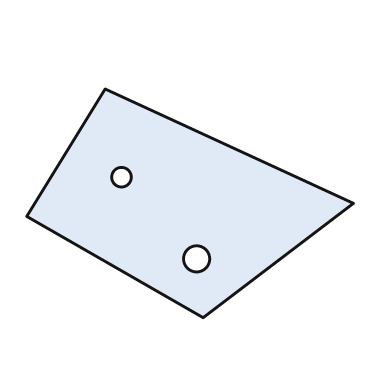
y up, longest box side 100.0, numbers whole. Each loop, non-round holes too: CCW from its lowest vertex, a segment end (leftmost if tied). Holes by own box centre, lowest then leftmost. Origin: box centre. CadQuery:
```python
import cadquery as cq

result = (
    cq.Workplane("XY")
    .moveTo(4.0, -35.0)
    .lineTo(50.0, 0.0)
    .lineTo(-26.0, 35.0)
    .lineTo(-50.0, -4.0)
    .close()
    .moveTo(2.0, -17.0)
    .circle(4.0)
    .moveTo(-21.0, 8.0)
    .circle(3.0)
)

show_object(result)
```